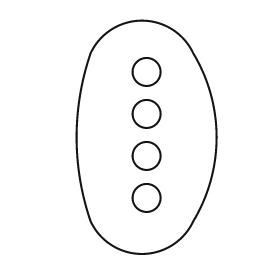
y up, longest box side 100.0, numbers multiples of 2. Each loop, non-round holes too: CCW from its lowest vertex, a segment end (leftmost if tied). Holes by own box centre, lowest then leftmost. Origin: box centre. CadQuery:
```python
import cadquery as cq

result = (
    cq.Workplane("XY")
    .moveTo(-24.0, -36.0)
    .threePointArc((-2.0, -50.0), (20.0, -36.0))
    .threePointArc((30.0, 0.0), (20.0, 36.0))
    .threePointArc((-2.0, 50.0), (-24.0, 36.0))
    .threePointArc((-30.0, 0.0), (-24.0, -36.0))
    .close()
    .moveTo(0.0, -26.0)
    .circle(6.0)
    .moveTo(0.0, -8.0)
    .circle(6.0)
    .moveTo(0.0, 10.0)
    .circle(6.0)
    .moveTo(0.0, 28.0)
    .circle(6.0)
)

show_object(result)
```